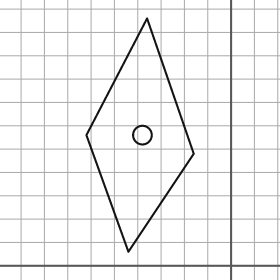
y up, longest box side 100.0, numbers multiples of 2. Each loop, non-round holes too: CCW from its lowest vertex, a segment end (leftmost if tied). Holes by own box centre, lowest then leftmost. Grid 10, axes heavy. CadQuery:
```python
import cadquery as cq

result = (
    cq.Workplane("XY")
    .moveTo(-44.0, 6.0)
    .lineTo(-16.0, 48.0)
    .lineTo(-36.0, 106.0)
    .lineTo(-62.0, 56.0)
    .close()
    .moveTo(-38.0, 56.0)
    .circle(4.0)
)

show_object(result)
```